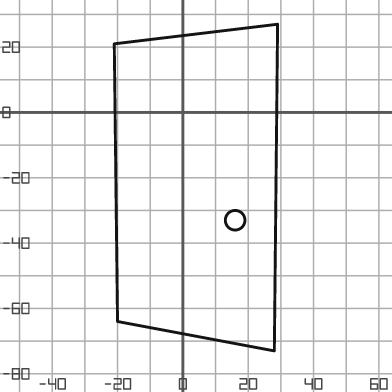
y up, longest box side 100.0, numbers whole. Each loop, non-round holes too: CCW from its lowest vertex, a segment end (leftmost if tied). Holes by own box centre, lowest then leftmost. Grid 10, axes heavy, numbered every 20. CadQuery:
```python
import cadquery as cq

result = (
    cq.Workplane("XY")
    .moveTo(28.0, -73.0)
    .lineTo(29.0, 27.0)
    .lineTo(-21.0, 21.0)
    .lineTo(-20.0, -64.0)
    .close()
    .moveTo(16.0, -33.0)
    .circle(3.0)
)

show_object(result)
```